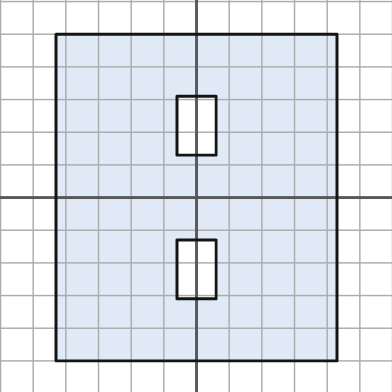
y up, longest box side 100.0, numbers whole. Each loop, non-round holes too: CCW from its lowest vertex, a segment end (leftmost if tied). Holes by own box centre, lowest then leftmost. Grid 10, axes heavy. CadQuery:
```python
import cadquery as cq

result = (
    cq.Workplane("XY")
    .moveTo(-43.0, -50.0)
    .lineTo(43.0, -50.0)
    .lineTo(43.0, 50.0)
    .lineTo(-43.0, 50.0)
    .close()
    .moveTo(-6.0, -31.0)
    .lineTo(6.0, -31.0)
    .lineTo(6.0, -13.0)
    .lineTo(-6.0, -13.0)
    .close()
    .moveTo(-6.0, 13.0)
    .lineTo(6.0, 13.0)
    .lineTo(6.0, 31.0)
    .lineTo(-6.0, 31.0)
    .close()
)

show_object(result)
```